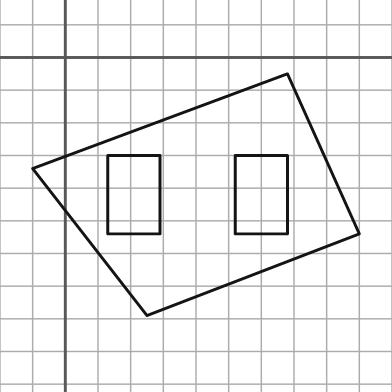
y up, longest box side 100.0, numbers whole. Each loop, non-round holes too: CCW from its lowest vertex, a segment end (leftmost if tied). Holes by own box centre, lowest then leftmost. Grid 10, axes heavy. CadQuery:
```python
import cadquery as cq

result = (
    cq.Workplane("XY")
    .moveTo(25.0, -79.0)
    .lineTo(90.0, -54.0)
    .lineTo(68.0, -5.0)
    .lineTo(-10.0, -34.0)
    .close()
    .moveTo(13.0, -54.0)
    .lineTo(29.0, -54.0)
    .lineTo(29.0, -30.0)
    .lineTo(13.0, -30.0)
    .close()
    .moveTo(52.0, -54.0)
    .lineTo(68.0, -54.0)
    .lineTo(68.0, -30.0)
    .lineTo(52.0, -30.0)
    .close()
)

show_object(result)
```